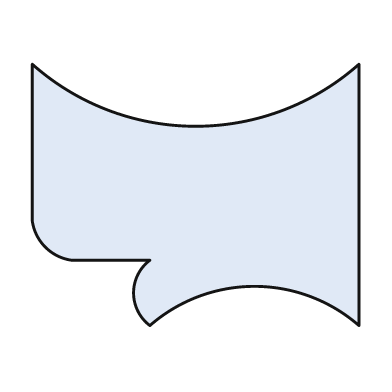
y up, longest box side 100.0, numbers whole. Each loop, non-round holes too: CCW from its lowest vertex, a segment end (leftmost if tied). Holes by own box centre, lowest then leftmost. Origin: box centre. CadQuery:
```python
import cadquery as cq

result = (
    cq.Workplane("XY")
    .moveTo(-14.0, -40.0)
    .threePointArc((18.0, -28.0), (50.0, -40.0))
    .lineTo(50.0, 40.0)
    .threePointArc((0.0, 21.0), (-50.0, 40.0))
    .lineTo(-50.0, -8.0)
    .threePointArc((-46.0, -16.0), (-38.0, -20.0))
    .lineTo(-14.0, -20.0)
    .threePointArc((-19.0, -30.0), (-14.0, -40.0))
    .close()
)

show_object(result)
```